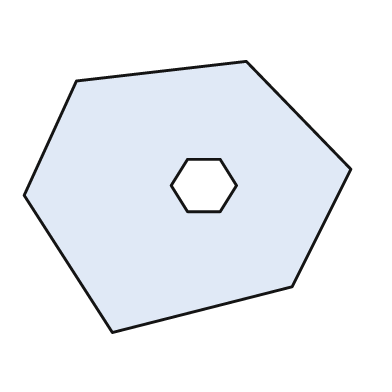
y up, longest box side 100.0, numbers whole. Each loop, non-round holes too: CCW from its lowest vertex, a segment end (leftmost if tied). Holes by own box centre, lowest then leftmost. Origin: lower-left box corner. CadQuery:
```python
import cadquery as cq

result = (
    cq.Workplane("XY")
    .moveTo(27.0, 0.0)
    .lineTo(82.0, 14.0)
    .lineTo(100.0, 50.0)
    .lineTo(68.0, 83.0)
    .lineTo(16.0, 77.0)
    .lineTo(0.0, 42.0)
    .close()
    .moveTo(50.0, 37.0)
    .lineTo(60.0, 37.0)
    .lineTo(65.0, 45.0)
    .lineTo(60.0, 53.0)
    .lineTo(50.0, 53.0)
    .lineTo(45.0, 45.0)
    .close()
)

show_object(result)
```